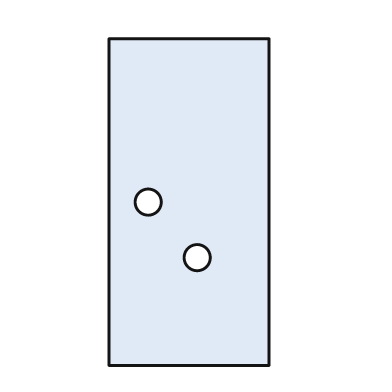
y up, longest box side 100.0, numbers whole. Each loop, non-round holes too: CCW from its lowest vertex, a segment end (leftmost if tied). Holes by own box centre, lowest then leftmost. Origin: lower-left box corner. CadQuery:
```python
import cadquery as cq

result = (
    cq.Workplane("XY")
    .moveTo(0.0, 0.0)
    .lineTo(49.0, 0.0)
    .lineTo(49.0, 100.0)
    .lineTo(0.0, 100.0)
    .close()
    .moveTo(27.0, 33.0)
    .circle(4.0)
    .moveTo(12.0, 50.0)
    .circle(4.0)
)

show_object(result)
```